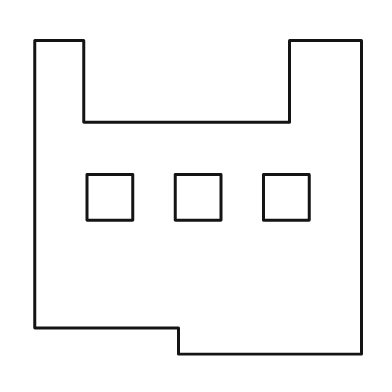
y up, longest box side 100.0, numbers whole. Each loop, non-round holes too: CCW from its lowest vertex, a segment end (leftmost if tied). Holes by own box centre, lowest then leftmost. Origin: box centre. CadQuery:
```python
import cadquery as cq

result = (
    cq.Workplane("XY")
    .moveTo(-6.0, -48.0)
    .lineTo(50.0, -48.0)
    .lineTo(50.0, 48.0)
    .lineTo(28.0, 48.0)
    .lineTo(28.0, 23.0)
    .lineTo(-35.0, 23.0)
    .lineTo(-35.0, 48.0)
    .lineTo(-50.0, 48.0)
    .lineTo(-50.0, -40.0)
    .lineTo(-6.0, -40.0)
    .close()
    .moveTo(-34.0, -7.0)
    .lineTo(-20.0, -7.0)
    .lineTo(-20.0, 7.0)
    .lineTo(-34.0, 7.0)
    .close()
    .moveTo(-7.0, -7.0)
    .lineTo(7.0, -7.0)
    .lineTo(7.0, 7.0)
    .lineTo(-7.0, 7.0)
    .close()
    .moveTo(20.0, -7.0)
    .lineTo(34.0, -7.0)
    .lineTo(34.0, 7.0)
    .lineTo(20.0, 7.0)
    .close()
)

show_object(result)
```